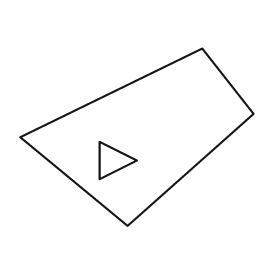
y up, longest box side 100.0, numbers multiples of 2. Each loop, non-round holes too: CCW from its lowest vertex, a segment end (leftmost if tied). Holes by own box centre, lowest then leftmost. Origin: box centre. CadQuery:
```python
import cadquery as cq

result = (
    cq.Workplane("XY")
    .moveTo(-4.0, -38.0)
    .lineTo(50.0, 10.0)
    .lineTo(28.0, 38.0)
    .lineTo(-50.0, 0.0)
    .close()
    .moveTo(-16.0, -18.0)
    .lineTo(0.0, -10.0)
    .lineTo(-16.0, -2.0)
    .close()
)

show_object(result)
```